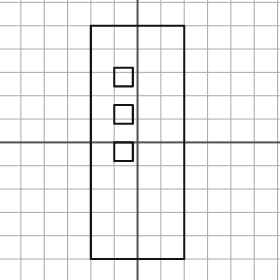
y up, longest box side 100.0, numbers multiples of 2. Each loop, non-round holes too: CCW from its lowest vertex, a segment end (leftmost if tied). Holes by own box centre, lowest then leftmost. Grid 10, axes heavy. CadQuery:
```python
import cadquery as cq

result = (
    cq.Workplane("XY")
    .moveTo(-20.0, -50.0)
    .lineTo(20.0, -50.0)
    .lineTo(20.0, 50.0)
    .lineTo(-20.0, 50.0)
    .close()
    .moveTo(-10.0, -8.0)
    .lineTo(-2.0, -8.0)
    .lineTo(-2.0, 0.0)
    .lineTo(-10.0, 0.0)
    .close()
    .moveTo(-10.0, 8.0)
    .lineTo(-2.0, 8.0)
    .lineTo(-2.0, 16.0)
    .lineTo(-10.0, 16.0)
    .close()
    .moveTo(-10.0, 24.0)
    .lineTo(-2.0, 24.0)
    .lineTo(-2.0, 32.0)
    .lineTo(-10.0, 32.0)
    .close()
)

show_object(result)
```